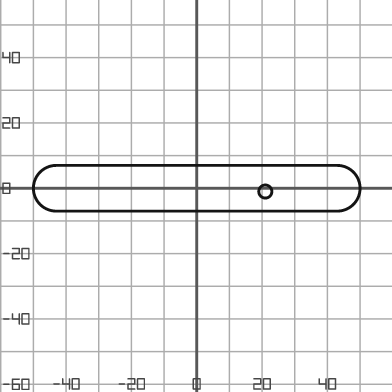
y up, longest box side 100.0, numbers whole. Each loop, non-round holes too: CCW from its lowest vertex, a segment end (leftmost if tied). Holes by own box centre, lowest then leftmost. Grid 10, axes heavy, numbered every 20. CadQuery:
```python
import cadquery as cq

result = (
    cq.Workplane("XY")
    .moveTo(-43.0, -7.0)
    .lineTo(43.0, -7.0)
    .threePointArc((50.0, 0.0), (43.0, 7.0))
    .lineTo(-43.0, 7.0)
    .threePointArc((-50.0, 0.0), (-43.0, -7.0))
    .close()
    .moveTo(21.0, -1.0)
    .circle(2.0)
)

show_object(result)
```